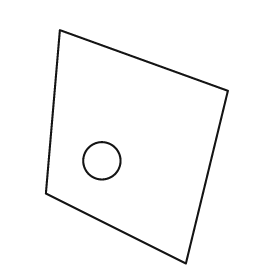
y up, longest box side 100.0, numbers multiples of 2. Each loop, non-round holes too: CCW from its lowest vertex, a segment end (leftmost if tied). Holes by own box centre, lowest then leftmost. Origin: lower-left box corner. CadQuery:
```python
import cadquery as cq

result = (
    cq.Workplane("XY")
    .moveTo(60.0, 0.0)
    .lineTo(78.0, 74.0)
    .lineTo(6.0, 100.0)
    .lineTo(0.0, 30.0)
    .close()
    .moveTo(24.0, 44.0)
    .circle(8.0)
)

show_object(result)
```